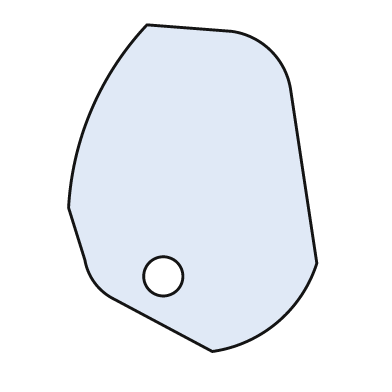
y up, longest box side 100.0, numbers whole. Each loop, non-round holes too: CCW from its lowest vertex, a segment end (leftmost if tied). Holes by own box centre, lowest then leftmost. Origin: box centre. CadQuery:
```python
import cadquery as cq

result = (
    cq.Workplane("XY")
    .moveTo(6.0, -50.0)
    .threePointArc((26.0, -41.0), (38.0, -23.0))
    .lineTo(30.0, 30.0)
    .threePointArc((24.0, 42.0), (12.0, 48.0))
    .lineTo(-14.0, 50.0)
    .threePointArc((-31.0, 24.0), (-38.0, -6.0))
    .lineTo(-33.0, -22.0)
    .threePointArc((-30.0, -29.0), (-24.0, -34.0))
    .close()
    .moveTo(-9.0, -27.0)
    .circle(6.0)
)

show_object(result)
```